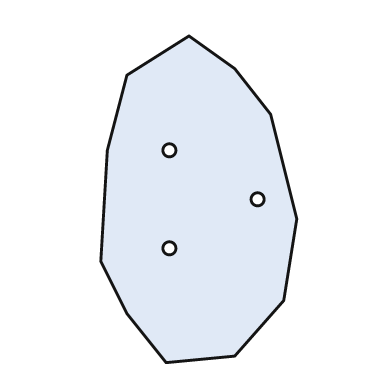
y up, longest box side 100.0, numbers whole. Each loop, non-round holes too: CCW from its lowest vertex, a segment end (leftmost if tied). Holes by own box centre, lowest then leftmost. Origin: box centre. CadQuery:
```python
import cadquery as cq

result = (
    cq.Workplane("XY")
    .moveTo(-10.0, -50.0)
    .lineTo(11.0, -48.0)
    .lineTo(26.0, -31.0)
    .lineTo(30.0, -6.0)
    .lineTo(22.0, 26.0)
    .lineTo(11.0, 40.0)
    .lineTo(-3.0, 50.0)
    .lineTo(-22.0, 38.0)
    .lineTo(-28.0, 15.0)
    .lineTo(-30.0, -19.0)
    .lineTo(-22.0, -35.0)
    .close()
    .moveTo(-9.0, -15.0)
    .circle(2.0)
    .moveTo(18.0, 0.0)
    .circle(2.0)
    .moveTo(-9.0, 15.0)
    .circle(2.0)
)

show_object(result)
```